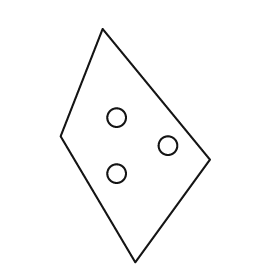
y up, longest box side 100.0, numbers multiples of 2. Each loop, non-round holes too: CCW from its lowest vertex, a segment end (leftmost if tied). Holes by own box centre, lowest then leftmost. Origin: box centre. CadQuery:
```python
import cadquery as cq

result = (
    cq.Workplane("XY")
    .moveTo(0.0, -50.0)
    .lineTo(32.0, -6.0)
    .lineTo(-14.0, 50.0)
    .lineTo(-32.0, 4.0)
    .close()
    .moveTo(-8.0, -12.0)
    .circle(4.0)
    .moveTo(14.0, 0.0)
    .circle(4.0)
    .moveTo(-8.0, 12.0)
    .circle(4.0)
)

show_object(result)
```